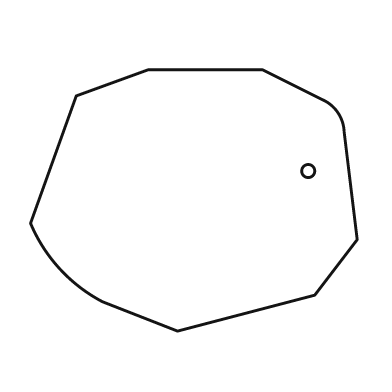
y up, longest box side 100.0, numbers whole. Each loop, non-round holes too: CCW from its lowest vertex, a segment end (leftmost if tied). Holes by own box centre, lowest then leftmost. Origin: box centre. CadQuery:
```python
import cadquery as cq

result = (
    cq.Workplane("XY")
    .moveTo(-5.0, -40.0)
    .lineTo(37.0, -29.0)
    .lineTo(50.0, -12.0)
    .lineTo(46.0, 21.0)
    .threePointArc((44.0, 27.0), (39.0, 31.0))
    .lineTo(21.0, 40.0)
    .lineTo(-14.0, 40.0)
    .lineTo(-36.0, 32.0)
    .lineTo(-50.0, -7.0)
    .threePointArc((-41.0, -21.0), (-28.0, -31.0))
    .close()
    .moveTo(35.0, 9.0)
    .circle(2.0)
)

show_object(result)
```